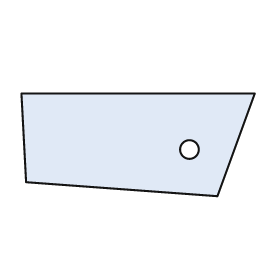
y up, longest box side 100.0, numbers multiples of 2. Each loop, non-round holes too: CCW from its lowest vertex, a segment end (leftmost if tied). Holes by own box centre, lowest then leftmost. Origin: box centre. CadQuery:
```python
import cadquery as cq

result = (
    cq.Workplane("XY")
    .moveTo(34.0, -22.0)
    .lineTo(50.0, 22.0)
    .lineTo(-50.0, 22.0)
    .lineTo(-48.0, -16.0)
    .close()
    .moveTo(22.0, -2.0)
    .circle(4.0)
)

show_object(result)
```